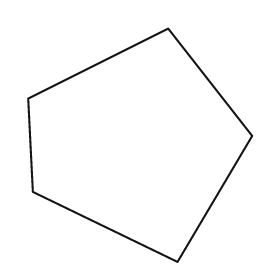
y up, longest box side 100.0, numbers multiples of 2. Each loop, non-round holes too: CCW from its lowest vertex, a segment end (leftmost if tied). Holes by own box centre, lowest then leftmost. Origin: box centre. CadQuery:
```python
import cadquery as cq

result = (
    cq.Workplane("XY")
    .moveTo(16.0, -50.0)
    .lineTo(48.0, 4.0)
    .lineTo(12.0, 50.0)
    .lineTo(-48.0, 20.0)
    .lineTo(-46.0, -20.0)
    .close()
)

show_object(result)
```